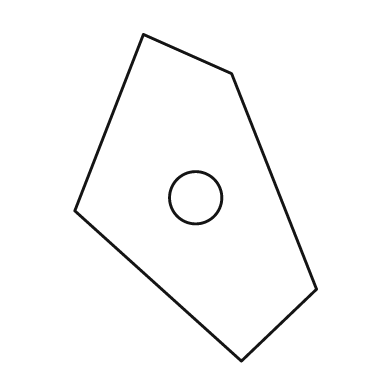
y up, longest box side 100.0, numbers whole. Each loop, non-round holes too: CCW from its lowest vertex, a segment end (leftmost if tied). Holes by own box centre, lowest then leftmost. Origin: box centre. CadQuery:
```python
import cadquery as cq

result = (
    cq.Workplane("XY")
    .moveTo(14.0, -50.0)
    .lineTo(37.0, -28.0)
    .lineTo(11.0, 38.0)
    .lineTo(-16.0, 50.0)
    .lineTo(-37.0, -4.0)
    .close()
    .moveTo(0.0, 0.0)
    .circle(8.0)
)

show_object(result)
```